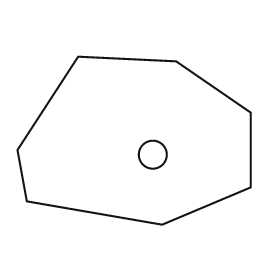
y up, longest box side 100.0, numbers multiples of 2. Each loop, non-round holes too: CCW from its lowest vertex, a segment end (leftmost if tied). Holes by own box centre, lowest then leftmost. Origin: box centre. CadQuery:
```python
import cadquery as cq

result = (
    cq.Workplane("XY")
    .moveTo(12.0, -36.0)
    .lineTo(50.0, -20.0)
    .lineTo(50.0, 12.0)
    .lineTo(18.0, 34.0)
    .lineTo(-24.0, 36.0)
    .lineTo(-50.0, -4.0)
    .lineTo(-46.0, -26.0)
    .close()
    .moveTo(8.0, -6.0)
    .circle(6.0)
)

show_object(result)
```